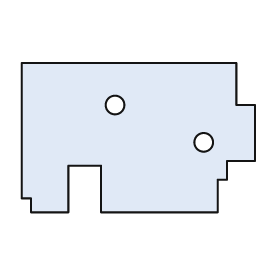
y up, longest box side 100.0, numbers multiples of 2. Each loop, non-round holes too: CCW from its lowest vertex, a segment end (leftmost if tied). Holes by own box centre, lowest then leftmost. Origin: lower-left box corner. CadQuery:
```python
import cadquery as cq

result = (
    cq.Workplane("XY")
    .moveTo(4.0, 0.0)
    .lineTo(20.0, 0.0)
    .lineTo(20.0, 20.0)
    .lineTo(34.0, 20.0)
    .lineTo(34.0, 0.0)
    .lineTo(84.0, 0.0)
    .lineTo(84.0, 14.0)
    .lineTo(88.0, 14.0)
    .lineTo(88.0, 22.0)
    .lineTo(100.0, 22.0)
    .lineTo(100.0, 46.0)
    .lineTo(92.0, 46.0)
    .lineTo(92.0, 64.0)
    .lineTo(0.0, 64.0)
    .lineTo(0.0, 6.0)
    .lineTo(4.0, 6.0)
    .close()
    .moveTo(78.0, 30.0)
    .circle(4.0)
    .moveTo(40.0, 46.0)
    .circle(4.0)
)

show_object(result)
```